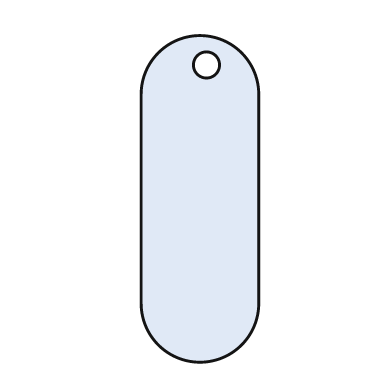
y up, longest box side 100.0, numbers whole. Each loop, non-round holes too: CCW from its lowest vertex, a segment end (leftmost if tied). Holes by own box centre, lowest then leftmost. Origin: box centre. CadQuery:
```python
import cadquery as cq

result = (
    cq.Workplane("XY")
    .moveTo(-18.0, -32.0)
    .threePointArc((0.0, -50.0), (18.0, -32.0))
    .lineTo(18.0, 32.0)
    .threePointArc((0.0, 50.0), (-18.0, 32.0))
    .close()
    .moveTo(2.0, 41.0)
    .circle(4.0)
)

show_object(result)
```